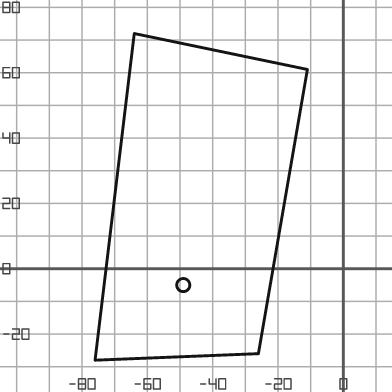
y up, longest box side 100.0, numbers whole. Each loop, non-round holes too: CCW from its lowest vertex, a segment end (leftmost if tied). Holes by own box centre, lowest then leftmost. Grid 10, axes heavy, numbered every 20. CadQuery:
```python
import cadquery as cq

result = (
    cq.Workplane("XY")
    .moveTo(-76.0, -28.0)
    .lineTo(-26.0, -26.0)
    .lineTo(-11.0, 61.0)
    .lineTo(-64.0, 72.0)
    .close()
    .moveTo(-49.0, -5.0)
    .circle(2.0)
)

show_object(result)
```